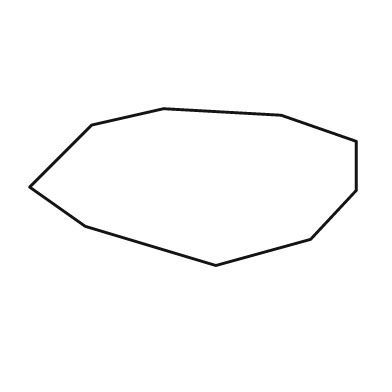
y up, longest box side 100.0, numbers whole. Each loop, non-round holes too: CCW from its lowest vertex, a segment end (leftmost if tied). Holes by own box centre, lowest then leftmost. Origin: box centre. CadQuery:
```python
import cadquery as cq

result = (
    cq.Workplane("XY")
    .moveTo(7.0, -24.0)
    .lineTo(36.0, -16.0)
    .lineTo(50.0, -1.0)
    .lineTo(50.0, 14.0)
    .lineTo(27.0, 22.0)
    .lineTo(-9.0, 24.0)
    .lineTo(-31.0, 19.0)
    .lineTo(-50.0, 0.0)
    .lineTo(-33.0, -12.0)
    .close()
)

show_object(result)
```